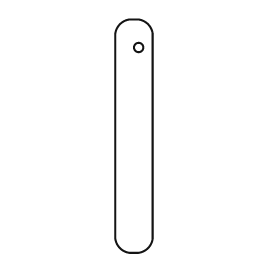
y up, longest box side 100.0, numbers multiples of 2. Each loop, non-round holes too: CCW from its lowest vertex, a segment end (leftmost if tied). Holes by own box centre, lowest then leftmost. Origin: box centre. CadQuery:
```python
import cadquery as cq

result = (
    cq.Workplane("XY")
    .moveTo(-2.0, -50.0)
    .lineTo(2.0, -50.0)
    .threePointArc((6.0, -48.0), (8.0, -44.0))
    .lineTo(8.0, 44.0)
    .threePointArc((6.0, 48.0), (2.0, 50.0))
    .lineTo(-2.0, 50.0)
    .threePointArc((-6.0, 48.0), (-8.0, 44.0))
    .lineTo(-8.0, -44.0)
    .threePointArc((-6.0, -48.0), (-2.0, -50.0))
    .close()
    .moveTo(2.0, 38.0)
    .circle(2.0)
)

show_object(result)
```